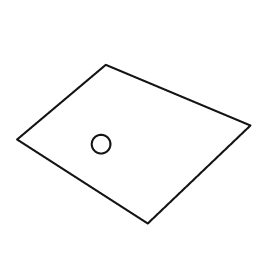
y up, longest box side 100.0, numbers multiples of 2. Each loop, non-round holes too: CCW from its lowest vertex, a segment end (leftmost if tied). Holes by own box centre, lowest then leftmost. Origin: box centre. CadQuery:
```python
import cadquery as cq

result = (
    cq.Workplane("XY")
    .moveTo(6.0, -34.0)
    .lineTo(50.0, 8.0)
    .lineTo(-12.0, 34.0)
    .lineTo(-50.0, 2.0)
    .close()
    .moveTo(-14.0, 0.0)
    .circle(4.0)
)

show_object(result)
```